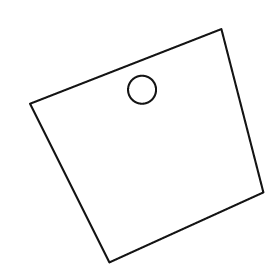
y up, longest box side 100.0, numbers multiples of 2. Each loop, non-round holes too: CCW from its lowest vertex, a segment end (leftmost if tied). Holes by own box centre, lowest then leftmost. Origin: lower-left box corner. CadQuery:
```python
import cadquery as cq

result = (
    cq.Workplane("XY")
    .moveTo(34.0, 0.0)
    .lineTo(100.0, 30.0)
    .lineTo(82.0, 100.0)
    .lineTo(0.0, 68.0)
    .close()
    .moveTo(48.0, 74.0)
    .circle(6.0)
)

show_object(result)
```